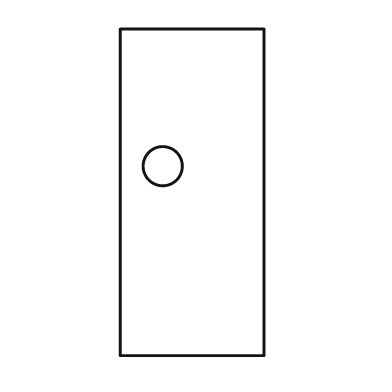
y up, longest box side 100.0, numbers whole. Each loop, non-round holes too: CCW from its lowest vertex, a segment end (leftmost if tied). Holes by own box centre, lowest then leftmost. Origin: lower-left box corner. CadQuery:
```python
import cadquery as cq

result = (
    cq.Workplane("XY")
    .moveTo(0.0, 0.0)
    .lineTo(44.0, 0.0)
    .lineTo(44.0, 100.0)
    .lineTo(0.0, 100.0)
    .close()
    .moveTo(13.0, 58.0)
    .circle(6.0)
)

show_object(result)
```